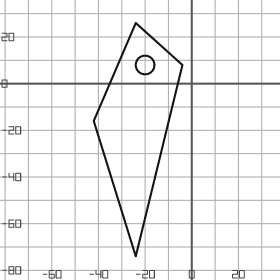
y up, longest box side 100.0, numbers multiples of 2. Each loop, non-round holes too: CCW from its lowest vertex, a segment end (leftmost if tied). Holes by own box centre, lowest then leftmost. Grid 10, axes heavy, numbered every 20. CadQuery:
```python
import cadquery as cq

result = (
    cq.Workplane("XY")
    .moveTo(-24.0, -74.0)
    .lineTo(-4.0, 8.0)
    .lineTo(-24.0, 26.0)
    .lineTo(-42.0, -16.0)
    .close()
    .moveTo(-20.0, 8.0)
    .circle(4.0)
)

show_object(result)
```